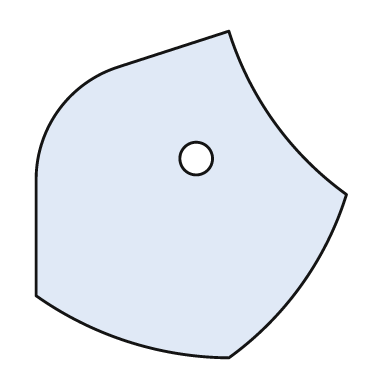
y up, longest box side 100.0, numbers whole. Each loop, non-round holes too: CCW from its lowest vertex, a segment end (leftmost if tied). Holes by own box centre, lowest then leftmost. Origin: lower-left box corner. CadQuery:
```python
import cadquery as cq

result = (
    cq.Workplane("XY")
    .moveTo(59.0, 0.0)
    .threePointArc((81.0, 22.0), (95.0, 50.0))
    .threePointArc((73.0, 72.0), (59.0, 100.0))
    .lineTo(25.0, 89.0)
    .threePointArc((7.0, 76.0), (0.0, 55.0))
    .lineTo(0.0, 19.0)
    .threePointArc((28.0, 5.0), (59.0, 0.0))
    .close()
    .moveTo(49.0, 61.0)
    .circle(5.0)
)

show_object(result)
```